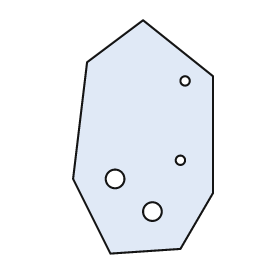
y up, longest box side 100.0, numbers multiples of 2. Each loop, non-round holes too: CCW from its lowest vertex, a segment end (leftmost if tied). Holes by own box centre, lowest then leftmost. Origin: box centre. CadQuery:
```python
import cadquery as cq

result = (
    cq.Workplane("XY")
    .moveTo(-14.0, -50.0)
    .lineTo(16.0, -48.0)
    .lineTo(30.0, -24.0)
    .lineTo(30.0, 26.0)
    .lineTo(0.0, 50.0)
    .lineTo(-24.0, 32.0)
    .lineTo(-30.0, -18.0)
    .close()
    .moveTo(4.0, -32.0)
    .circle(4.0)
    .moveTo(-12.0, -18.0)
    .circle(4.0)
    .moveTo(16.0, -10.0)
    .circle(2.0)
    .moveTo(18.0, 24.0)
    .circle(2.0)
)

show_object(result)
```